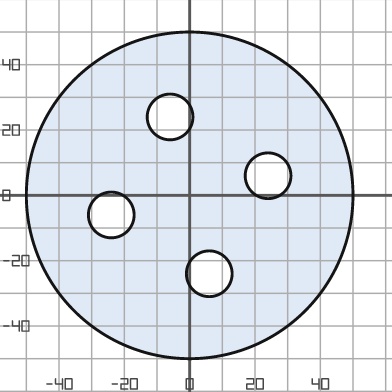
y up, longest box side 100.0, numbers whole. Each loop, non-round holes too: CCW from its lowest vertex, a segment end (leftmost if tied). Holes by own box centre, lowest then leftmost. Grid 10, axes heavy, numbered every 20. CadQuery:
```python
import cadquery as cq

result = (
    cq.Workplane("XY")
    .moveTo(0.0, 0.0)
    .circle(50.0)
    .moveTo(6.0, -24.0)
    .circle(7.0)
    .moveTo(-24.0, -6.0)
    .circle(7.0)
    .moveTo(24.0, 6.0)
    .circle(7.0)
    .moveTo(-6.0, 24.0)
    .circle(7.0)
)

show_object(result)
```